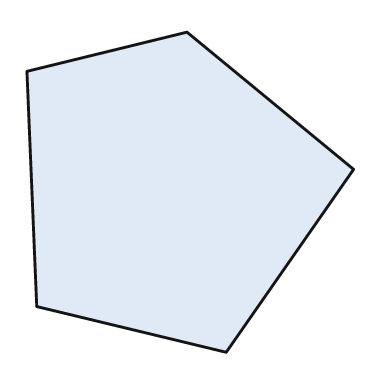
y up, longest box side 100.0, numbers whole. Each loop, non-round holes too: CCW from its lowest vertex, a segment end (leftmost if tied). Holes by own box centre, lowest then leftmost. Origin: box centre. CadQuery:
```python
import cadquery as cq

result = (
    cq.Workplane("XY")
    .moveTo(11.0, -49.0)
    .lineTo(50.0, 7.0)
    .lineTo(-1.0, 49.0)
    .lineTo(-50.0, 37.0)
    .lineTo(-47.0, -35.0)
    .close()
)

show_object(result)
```